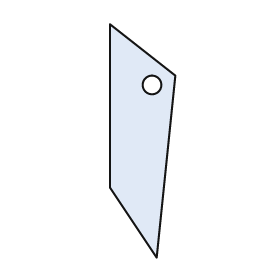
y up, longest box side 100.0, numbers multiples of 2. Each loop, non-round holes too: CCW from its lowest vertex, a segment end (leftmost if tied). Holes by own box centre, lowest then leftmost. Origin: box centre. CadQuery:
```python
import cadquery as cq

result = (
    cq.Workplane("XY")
    .moveTo(6.0, -50.0)
    .lineTo(14.0, 28.0)
    .lineTo(-14.0, 50.0)
    .lineTo(-14.0, -20.0)
    .close()
    .moveTo(4.0, 24.0)
    .circle(4.0)
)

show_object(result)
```